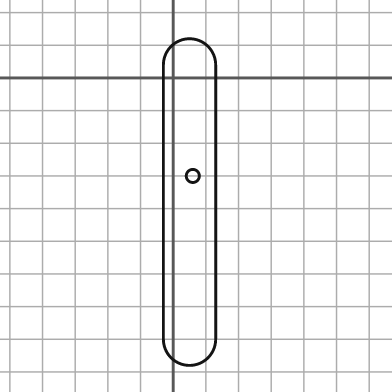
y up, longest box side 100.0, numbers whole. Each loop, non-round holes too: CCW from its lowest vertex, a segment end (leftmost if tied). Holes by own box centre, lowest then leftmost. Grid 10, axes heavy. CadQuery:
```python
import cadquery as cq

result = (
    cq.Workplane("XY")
    .moveTo(-3.0, -80.0)
    .threePointArc((5.0, -88.0), (13.0, -80.0))
    .lineTo(13.0, 4.0)
    .threePointArc((5.0, 12.0), (-3.0, 4.0))
    .close()
    .moveTo(6.0, -30.0)
    .circle(2.0)
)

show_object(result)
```